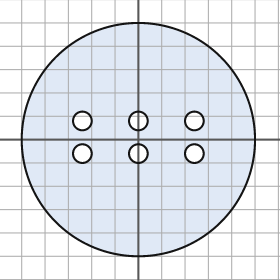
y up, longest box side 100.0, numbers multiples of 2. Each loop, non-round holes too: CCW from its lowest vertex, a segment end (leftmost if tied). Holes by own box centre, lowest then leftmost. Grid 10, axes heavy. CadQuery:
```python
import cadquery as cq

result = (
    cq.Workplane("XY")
    .moveTo(0.0, 0.0)
    .circle(50.0)
    .moveTo(-24.0, -6.0)
    .circle(4.0)
    .moveTo(0.0, -6.0)
    .circle(4.0)
    .moveTo(24.0, -6.0)
    .circle(4.0)
    .moveTo(-24.0, 8.0)
    .circle(4.0)
    .moveTo(0.0, 8.0)
    .circle(4.0)
    .moveTo(24.0, 8.0)
    .circle(4.0)
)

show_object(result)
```